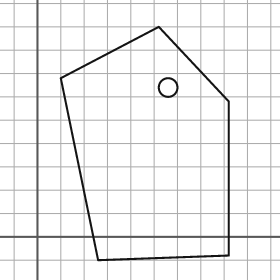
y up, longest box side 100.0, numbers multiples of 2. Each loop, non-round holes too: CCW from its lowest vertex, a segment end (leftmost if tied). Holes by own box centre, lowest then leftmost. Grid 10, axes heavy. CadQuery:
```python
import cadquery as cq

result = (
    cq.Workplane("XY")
    .moveTo(26.0, -10.0)
    .lineTo(82.0, -8.0)
    .lineTo(82.0, 58.0)
    .lineTo(52.0, 90.0)
    .lineTo(10.0, 68.0)
    .close()
    .moveTo(56.0, 64.0)
    .circle(4.0)
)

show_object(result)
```